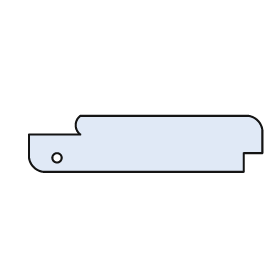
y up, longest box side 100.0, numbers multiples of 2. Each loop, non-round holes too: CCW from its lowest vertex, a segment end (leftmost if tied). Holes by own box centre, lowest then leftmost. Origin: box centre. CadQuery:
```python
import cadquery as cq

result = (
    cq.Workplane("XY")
    .moveTo(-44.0, -12.0)
    .lineTo(42.0, -12.0)
    .lineTo(42.0, -4.0)
    .lineTo(50.0, -4.0)
    .lineTo(50.0, 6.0)
    .threePointArc((48.0, 10.0), (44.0, 12.0))
    .lineTo(-28.0, 12.0)
    .threePointArc((-30.0, 8.0), (-28.0, 4.0))
    .lineTo(-50.0, 4.0)
    .lineTo(-50.0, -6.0)
    .threePointArc((-48.0, -10.0), (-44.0, -12.0))
    .close()
    .moveTo(-38.0, -6.0)
    .circle(2.0)
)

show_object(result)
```